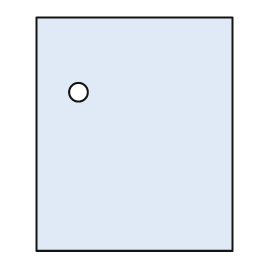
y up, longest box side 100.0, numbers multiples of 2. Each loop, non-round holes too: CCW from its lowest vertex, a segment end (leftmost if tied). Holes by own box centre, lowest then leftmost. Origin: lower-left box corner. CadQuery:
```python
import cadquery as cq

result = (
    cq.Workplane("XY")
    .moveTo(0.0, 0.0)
    .lineTo(84.0, 0.0)
    .lineTo(84.0, 100.0)
    .lineTo(0.0, 100.0)
    .close()
    .moveTo(18.0, 68.0)
    .circle(4.0)
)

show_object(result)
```